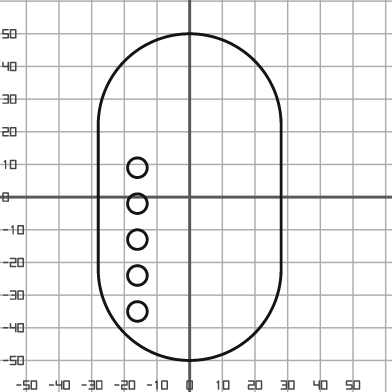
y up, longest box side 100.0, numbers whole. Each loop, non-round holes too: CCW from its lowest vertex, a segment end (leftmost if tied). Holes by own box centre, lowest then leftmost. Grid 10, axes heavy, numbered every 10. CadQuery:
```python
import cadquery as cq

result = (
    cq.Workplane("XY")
    .moveTo(-28.0, -22.0)
    .threePointArc((0.0, -50.0), (28.0, -22.0))
    .lineTo(28.0, 22.0)
    .threePointArc((0.0, 50.0), (-28.0, 22.0))
    .close()
    .moveTo(-16.0, -35.0)
    .circle(3.0)
    .moveTo(-16.0, -24.0)
    .circle(3.0)
    .moveTo(-16.0, -13.0)
    .circle(3.0)
    .moveTo(-16.0, -2.0)
    .circle(3.0)
    .moveTo(-16.0, 9.0)
    .circle(3.0)
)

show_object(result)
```